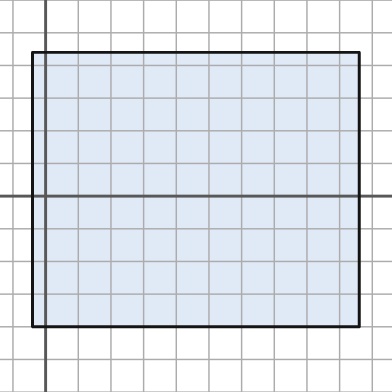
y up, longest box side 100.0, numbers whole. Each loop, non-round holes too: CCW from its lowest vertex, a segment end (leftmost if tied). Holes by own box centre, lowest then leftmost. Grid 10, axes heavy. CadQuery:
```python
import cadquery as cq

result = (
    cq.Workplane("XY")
    .moveTo(-4.0, -40.0)
    .lineTo(96.0, -40.0)
    .lineTo(96.0, 44.0)
    .lineTo(-4.0, 44.0)
    .close()
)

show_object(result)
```